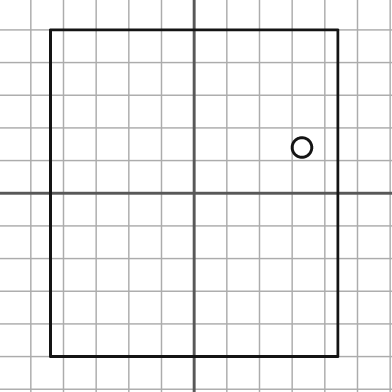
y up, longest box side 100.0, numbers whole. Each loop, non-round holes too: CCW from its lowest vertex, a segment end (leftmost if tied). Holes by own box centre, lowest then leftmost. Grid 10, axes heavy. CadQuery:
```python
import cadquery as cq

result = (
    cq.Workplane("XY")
    .moveTo(-44.0, -50.0)
    .lineTo(44.0, -50.0)
    .lineTo(44.0, 50.0)
    .lineTo(-44.0, 50.0)
    .close()
    .moveTo(33.0, 14.0)
    .circle(3.0)
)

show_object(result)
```